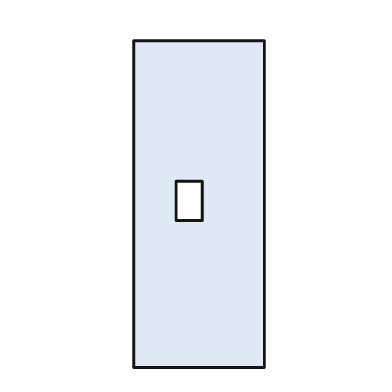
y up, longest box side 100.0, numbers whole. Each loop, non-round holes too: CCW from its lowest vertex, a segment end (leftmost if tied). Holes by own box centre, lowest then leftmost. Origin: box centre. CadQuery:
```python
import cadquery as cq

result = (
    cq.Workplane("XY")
    .moveTo(-20.0, -50.0)
    .lineTo(20.0, -50.0)
    .lineTo(20.0, 50.0)
    .lineTo(-20.0, 50.0)
    .close()
    .moveTo(-7.0, -5.0)
    .lineTo(1.0, -5.0)
    .lineTo(1.0, 7.0)
    .lineTo(-7.0, 7.0)
    .close()
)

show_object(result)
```